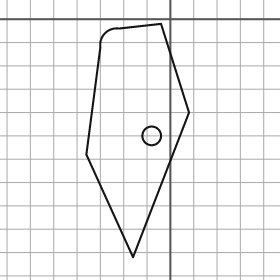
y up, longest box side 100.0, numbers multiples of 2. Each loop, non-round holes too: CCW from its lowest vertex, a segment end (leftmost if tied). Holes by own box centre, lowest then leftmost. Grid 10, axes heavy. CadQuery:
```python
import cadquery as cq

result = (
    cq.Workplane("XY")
    .moveTo(-16.0, -102.0)
    .lineTo(8.0, -40.0)
    .lineTo(-4.0, -2.0)
    .lineTo(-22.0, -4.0)
    .threePointArc((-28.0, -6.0), (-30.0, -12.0))
    .lineTo(-36.0, -58.0)
    .close()
    .moveTo(-8.0, -50.0)
    .circle(4.0)
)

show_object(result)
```